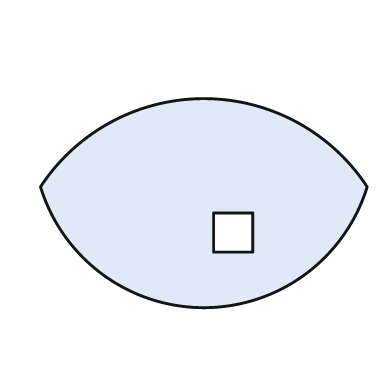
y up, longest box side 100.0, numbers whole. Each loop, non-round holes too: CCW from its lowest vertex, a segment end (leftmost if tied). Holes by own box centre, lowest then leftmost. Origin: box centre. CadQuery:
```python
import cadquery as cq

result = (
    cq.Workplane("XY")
    .moveTo(-50.0, 5.0)
    .threePointArc((0.0, -32.0), (50.0, 5.0))
    .threePointArc((0.0, 32.0), (-50.0, 5.0))
    .close()
    .moveTo(3.0, -15.0)
    .lineTo(15.0, -15.0)
    .lineTo(15.0, -3.0)
    .lineTo(3.0, -3.0)
    .close()
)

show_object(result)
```